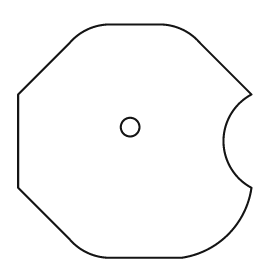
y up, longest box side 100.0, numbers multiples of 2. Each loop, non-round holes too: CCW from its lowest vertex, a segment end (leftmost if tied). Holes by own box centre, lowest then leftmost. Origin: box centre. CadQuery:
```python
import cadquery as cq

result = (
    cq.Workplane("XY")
    .moveTo(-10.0, -50.0)
    .lineTo(20.0, -50.0)
    .threePointArc((40.0, -40.0), (50.0, -20.0))
    .threePointArc((38.0, 0.0), (50.0, 20.0))
    .lineTo(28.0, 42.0)
    .threePointArc((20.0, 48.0), (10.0, 50.0))
    .lineTo(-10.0, 50.0)
    .threePointArc((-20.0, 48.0), (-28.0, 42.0))
    .lineTo(-50.0, 20.0)
    .lineTo(-50.0, -20.0)
    .lineTo(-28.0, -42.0)
    .threePointArc((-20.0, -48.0), (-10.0, -50.0))
    .close()
    .moveTo(-2.0, 6.0)
    .circle(4.0)
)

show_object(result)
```